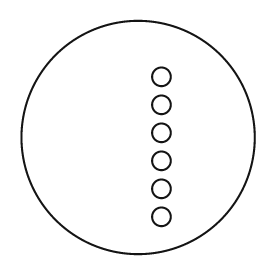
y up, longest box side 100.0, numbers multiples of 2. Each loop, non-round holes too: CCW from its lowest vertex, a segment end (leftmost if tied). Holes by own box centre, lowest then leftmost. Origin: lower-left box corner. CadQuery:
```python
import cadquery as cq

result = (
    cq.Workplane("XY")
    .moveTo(50.0, 50.0)
    .circle(50.0)
    .moveTo(60.0, 16.0)
    .circle(4.0)
    .moveTo(60.0, 28.0)
    .circle(4.0)
    .moveTo(60.0, 40.0)
    .circle(4.0)
    .moveTo(60.0, 52.0)
    .circle(4.0)
    .moveTo(60.0, 64.0)
    .circle(4.0)
    .moveTo(60.0, 76.0)
    .circle(4.0)
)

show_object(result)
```